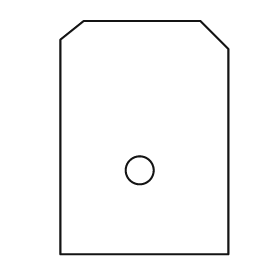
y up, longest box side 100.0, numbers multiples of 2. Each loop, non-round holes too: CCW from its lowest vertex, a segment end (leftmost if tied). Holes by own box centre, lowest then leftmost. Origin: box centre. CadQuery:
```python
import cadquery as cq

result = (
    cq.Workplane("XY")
    .moveTo(-36.0, -50.0)
    .lineTo(36.0, -50.0)
    .lineTo(36.0, 38.0)
    .lineTo(24.0, 50.0)
    .lineTo(-26.0, 50.0)
    .lineTo(-36.0, 42.0)
    .close()
    .moveTo(-2.0, -14.0)
    .circle(6.0)
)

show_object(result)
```